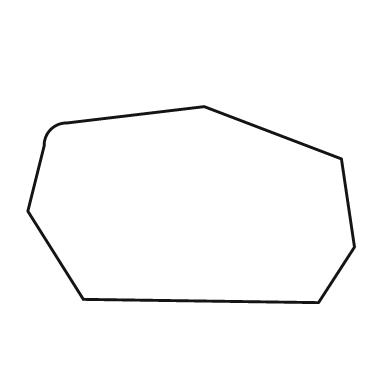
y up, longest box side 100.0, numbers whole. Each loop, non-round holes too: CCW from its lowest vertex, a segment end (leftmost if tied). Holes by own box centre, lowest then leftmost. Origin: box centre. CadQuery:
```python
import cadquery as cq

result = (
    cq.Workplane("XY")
    .moveTo(39.0, -30.0)
    .lineTo(50.0, -13.0)
    .lineTo(46.0, 14.0)
    .lineTo(4.0, 30.0)
    .lineTo(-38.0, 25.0)
    .threePointArc((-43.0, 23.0), (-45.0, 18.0))
    .lineTo(-50.0, -2.0)
    .lineTo(-33.0, -29.0)
    .close()
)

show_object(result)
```